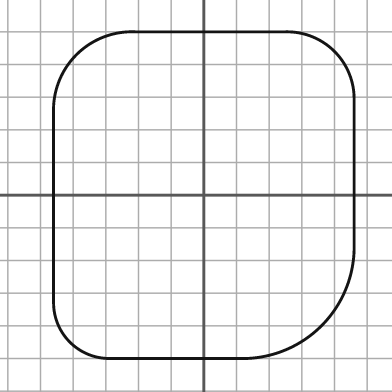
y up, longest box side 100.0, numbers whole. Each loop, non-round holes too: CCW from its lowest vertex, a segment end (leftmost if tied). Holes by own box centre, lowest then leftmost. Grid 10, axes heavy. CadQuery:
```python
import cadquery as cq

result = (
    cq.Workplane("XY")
    .moveTo(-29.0, -50.0)
    .lineTo(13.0, -50.0)
    .threePointArc((36.0, -40.0), (46.0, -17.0))
    .lineTo(46.0, 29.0)
    .threePointArc((40.0, 44.0), (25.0, 50.0))
    .lineTo(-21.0, 50.0)
    .threePointArc((-39.0, 43.0), (-46.0, 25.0))
    .lineTo(-46.0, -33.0)
    .threePointArc((-41.0, -45.0), (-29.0, -50.0))
    .close()
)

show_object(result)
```